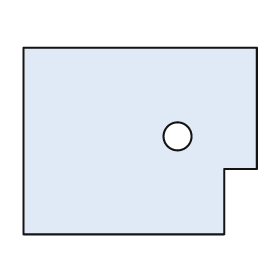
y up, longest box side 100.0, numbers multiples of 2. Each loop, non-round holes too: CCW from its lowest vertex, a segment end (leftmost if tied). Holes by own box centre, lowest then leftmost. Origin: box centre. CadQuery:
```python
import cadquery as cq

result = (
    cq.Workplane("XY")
    .moveTo(-50.0, -40.0)
    .lineTo(36.0, -40.0)
    .lineTo(36.0, -12.0)
    .lineTo(50.0, -12.0)
    .lineTo(50.0, 40.0)
    .lineTo(-50.0, 40.0)
    .close()
    .moveTo(16.0, 2.0)
    .circle(6.0)
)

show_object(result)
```